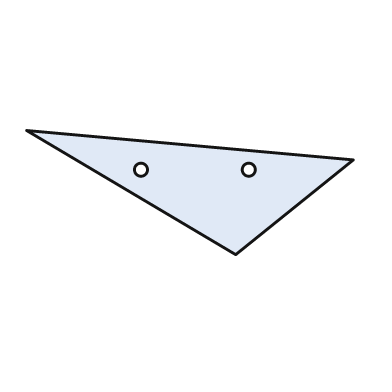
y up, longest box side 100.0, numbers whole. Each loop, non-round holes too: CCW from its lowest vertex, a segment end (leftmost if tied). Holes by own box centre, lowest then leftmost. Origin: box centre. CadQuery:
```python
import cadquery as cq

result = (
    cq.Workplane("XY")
    .moveTo(14.0, -19.0)
    .lineTo(50.0, 10.0)
    .lineTo(-50.0, 19.0)
    .close()
    .moveTo(-15.0, 7.0)
    .circle(2.0)
    .moveTo(18.0, 7.0)
    .circle(2.0)
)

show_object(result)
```